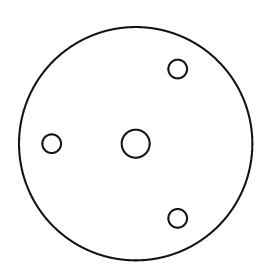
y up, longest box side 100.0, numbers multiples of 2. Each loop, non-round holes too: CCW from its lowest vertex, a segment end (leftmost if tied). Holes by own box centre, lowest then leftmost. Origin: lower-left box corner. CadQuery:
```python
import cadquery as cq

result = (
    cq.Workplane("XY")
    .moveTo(50.0, 50.0)
    .circle(50.0)
    .moveTo(68.0, 18.0)
    .circle(4.0)
    .moveTo(14.0, 50.0)
    .circle(4.0)
    .moveTo(50.0, 50.0)
    .circle(6.0)
    .moveTo(68.0, 82.0)
    .circle(4.0)
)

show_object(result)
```